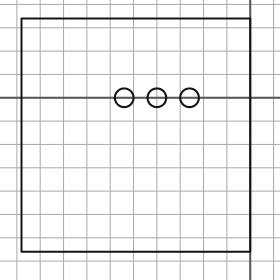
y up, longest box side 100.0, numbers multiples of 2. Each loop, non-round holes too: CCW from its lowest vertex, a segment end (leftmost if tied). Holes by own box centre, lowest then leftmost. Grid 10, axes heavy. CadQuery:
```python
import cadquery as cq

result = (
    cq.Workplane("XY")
    .moveTo(-98.0, -66.0)
    .lineTo(0.0, -66.0)
    .lineTo(0.0, 34.0)
    .lineTo(-98.0, 34.0)
    .close()
    .moveTo(-54.0, 0.0)
    .circle(4.0)
    .moveTo(-40.0, 0.0)
    .circle(4.0)
    .moveTo(-26.0, 0.0)
    .circle(4.0)
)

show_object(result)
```